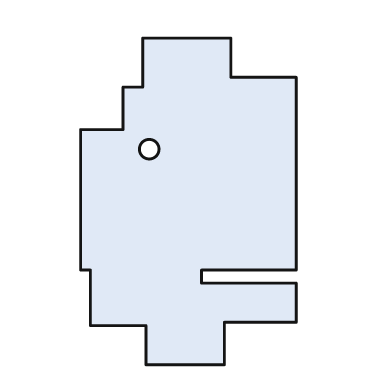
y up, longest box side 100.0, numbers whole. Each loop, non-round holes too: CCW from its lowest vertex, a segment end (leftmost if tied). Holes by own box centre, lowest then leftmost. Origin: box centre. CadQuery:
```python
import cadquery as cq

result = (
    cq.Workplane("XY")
    .moveTo(-13.0, -50.0)
    .lineTo(11.0, -50.0)
    .lineTo(11.0, -37.0)
    .lineTo(33.0, -37.0)
    .lineTo(33.0, -25.0)
    .lineTo(4.0, -25.0)
    .lineTo(4.0, -21.0)
    .lineTo(33.0, -21.0)
    .lineTo(33.0, 38.0)
    .lineTo(13.0, 38.0)
    .lineTo(13.0, 50.0)
    .lineTo(-14.0, 50.0)
    .lineTo(-14.0, 35.0)
    .lineTo(-20.0, 35.0)
    .lineTo(-20.0, 22.0)
    .lineTo(-33.0, 22.0)
    .lineTo(-33.0, -21.0)
    .lineTo(-30.0, -21.0)
    .lineTo(-30.0, -38.0)
    .lineTo(-13.0, -38.0)
    .close()
    .moveTo(-12.0, 16.0)
    .circle(3.0)
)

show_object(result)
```